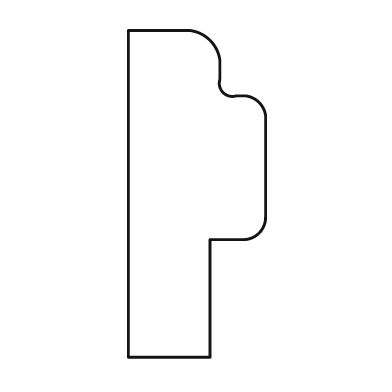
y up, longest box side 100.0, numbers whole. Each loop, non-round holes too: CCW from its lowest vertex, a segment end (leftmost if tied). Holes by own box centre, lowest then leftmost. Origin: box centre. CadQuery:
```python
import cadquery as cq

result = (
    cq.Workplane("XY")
    .moveTo(-21.0, -50.0)
    .lineTo(4.0, -50.0)
    .lineTo(4.0, -14.0)
    .lineTo(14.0, -14.0)
    .threePointArc((19.0, -12.0), (21.0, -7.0))
    .lineTo(21.0, 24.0)
    .threePointArc((19.0, 28.0), (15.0, 30.0))
    .lineTo(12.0, 30.0)
    .threePointArc((8.0, 31.0), (7.0, 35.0))
    .lineTo(7.0, 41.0)
    .threePointArc((4.0, 47.0), (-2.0, 50.0))
    .lineTo(-21.0, 50.0)
    .close()
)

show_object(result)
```